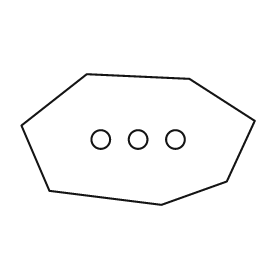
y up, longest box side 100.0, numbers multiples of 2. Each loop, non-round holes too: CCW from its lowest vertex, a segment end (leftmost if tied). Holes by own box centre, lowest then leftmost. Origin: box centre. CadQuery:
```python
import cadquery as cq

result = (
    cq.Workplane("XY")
    .moveTo(10.0, -28.0)
    .lineTo(38.0, -18.0)
    .lineTo(50.0, 8.0)
    .lineTo(22.0, 26.0)
    .lineTo(-22.0, 28.0)
    .lineTo(-50.0, 6.0)
    .lineTo(-38.0, -22.0)
    .close()
    .moveTo(-16.0, 0.0)
    .circle(4.0)
    .moveTo(0.0, 0.0)
    .circle(4.0)
    .moveTo(16.0, 0.0)
    .circle(4.0)
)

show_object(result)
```